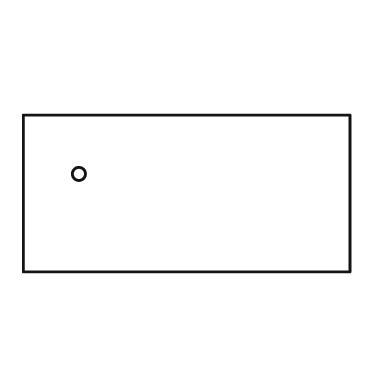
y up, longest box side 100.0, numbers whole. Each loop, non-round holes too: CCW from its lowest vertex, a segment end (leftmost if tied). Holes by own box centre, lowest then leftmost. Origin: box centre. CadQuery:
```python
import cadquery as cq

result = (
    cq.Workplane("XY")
    .moveTo(-50.0, -24.0)
    .lineTo(50.0, -24.0)
    .lineTo(50.0, 24.0)
    .lineTo(-50.0, 24.0)
    .close()
    .moveTo(-33.0, 6.0)
    .circle(2.0)
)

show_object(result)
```